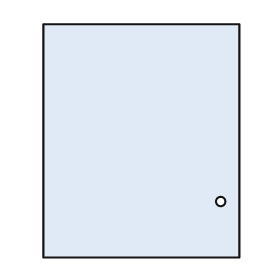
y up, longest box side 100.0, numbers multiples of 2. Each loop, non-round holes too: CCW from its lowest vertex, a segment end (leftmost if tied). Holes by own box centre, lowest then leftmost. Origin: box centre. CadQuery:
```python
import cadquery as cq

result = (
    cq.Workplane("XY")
    .moveTo(-42.0, -50.0)
    .lineTo(42.0, -50.0)
    .lineTo(42.0, 50.0)
    .lineTo(-42.0, 50.0)
    .close()
    .moveTo(34.0, -26.0)
    .circle(2.0)
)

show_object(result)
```